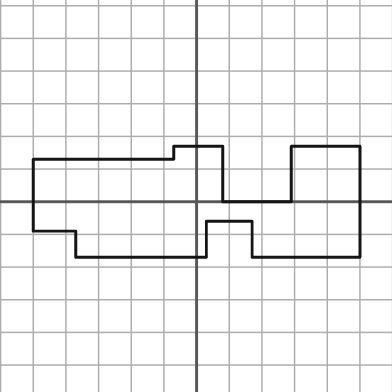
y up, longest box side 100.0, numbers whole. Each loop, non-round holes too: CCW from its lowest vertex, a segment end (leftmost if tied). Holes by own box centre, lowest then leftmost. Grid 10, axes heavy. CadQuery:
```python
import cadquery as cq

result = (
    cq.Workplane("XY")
    .moveTo(-37.0, -17.0)
    .lineTo(3.0, -17.0)
    .lineTo(3.0, -6.0)
    .lineTo(17.0, -6.0)
    .lineTo(17.0, -17.0)
    .lineTo(50.0, -17.0)
    .lineTo(50.0, 17.0)
    .lineTo(29.0, 17.0)
    .lineTo(29.0, 0.0)
    .lineTo(8.0, 0.0)
    .lineTo(8.0, 17.0)
    .lineTo(-7.0, 17.0)
    .lineTo(-7.0, 13.0)
    .lineTo(-50.0, 13.0)
    .lineTo(-50.0, -9.0)
    .lineTo(-37.0, -9.0)
    .close()
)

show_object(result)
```